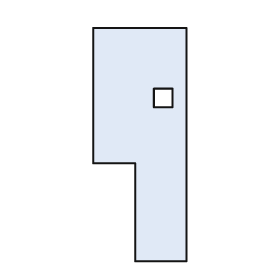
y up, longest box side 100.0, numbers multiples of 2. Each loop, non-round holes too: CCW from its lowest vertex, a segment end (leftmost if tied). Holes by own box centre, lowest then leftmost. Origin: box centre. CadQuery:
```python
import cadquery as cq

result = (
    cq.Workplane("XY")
    .moveTo(-2.0, -50.0)
    .lineTo(20.0, -50.0)
    .lineTo(20.0, 50.0)
    .lineTo(-20.0, 50.0)
    .lineTo(-20.0, -8.0)
    .lineTo(-2.0, -8.0)
    .close()
    .moveTo(6.0, 16.0)
    .lineTo(14.0, 16.0)
    .lineTo(14.0, 24.0)
    .lineTo(6.0, 24.0)
    .close()
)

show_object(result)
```